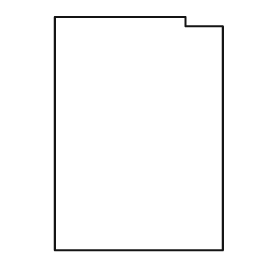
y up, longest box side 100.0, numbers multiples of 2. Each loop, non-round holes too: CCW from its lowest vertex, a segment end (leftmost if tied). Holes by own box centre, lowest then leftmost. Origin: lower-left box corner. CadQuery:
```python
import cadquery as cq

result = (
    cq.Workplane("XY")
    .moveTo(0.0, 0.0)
    .lineTo(72.0, 0.0)
    .lineTo(72.0, 96.0)
    .lineTo(56.0, 96.0)
    .lineTo(56.0, 100.0)
    .lineTo(0.0, 100.0)
    .close()
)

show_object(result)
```